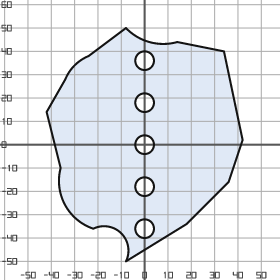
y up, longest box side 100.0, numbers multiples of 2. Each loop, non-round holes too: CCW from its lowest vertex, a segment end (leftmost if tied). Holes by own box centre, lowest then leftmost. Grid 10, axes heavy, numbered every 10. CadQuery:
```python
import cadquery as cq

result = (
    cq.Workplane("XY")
    .moveTo(-8.0, -50.0)
    .lineTo(18.0, -34.0)
    .lineTo(36.0, -16.0)
    .lineTo(42.0, 2.0)
    .lineTo(34.0, 40.0)
    .lineTo(14.0, 44.0)
    .threePointArc((2.0, 44.0), (-8.0, 50.0))
    .lineTo(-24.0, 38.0)
    .threePointArc((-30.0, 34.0), (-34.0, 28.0))
    .lineTo(-42.0, 14.0)
    .lineTo(-36.0, -10.0)
    .threePointArc((-34.0, -26.0), (-22.0, -36.0))
    .threePointArc((-10.0, -38.0), (-8.0, -50.0))
    .close()
    .moveTo(0.0, -36.0)
    .circle(4.0)
    .moveTo(0.0, -18.0)
    .circle(4.0)
    .moveTo(0.0, 0.0)
    .circle(4.0)
    .moveTo(0.0, 18.0)
    .circle(4.0)
    .moveTo(0.0, 36.0)
    .circle(4.0)
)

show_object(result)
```